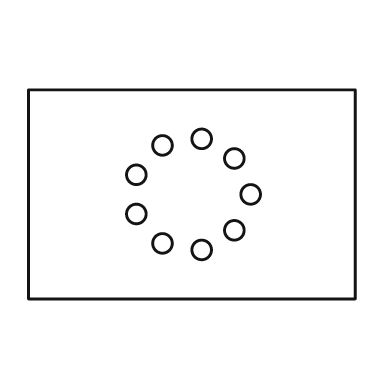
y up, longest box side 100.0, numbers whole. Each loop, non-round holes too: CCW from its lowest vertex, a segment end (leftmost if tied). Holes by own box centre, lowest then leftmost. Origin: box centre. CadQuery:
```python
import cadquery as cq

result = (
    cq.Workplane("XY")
    .moveTo(-50.0, -32.0)
    .lineTo(50.0, -32.0)
    .lineTo(50.0, 32.0)
    .lineTo(-50.0, 32.0)
    .close()
    .moveTo(3.0, -17.0)
    .circle(3.0)
    .moveTo(-9.0, -15.0)
    .circle(3.0)
    .moveTo(13.0, -11.0)
    .circle(3.0)
    .moveTo(-17.0, -6.0)
    .circle(3.0)
    .moveTo(18.0, 0.0)
    .circle(3.0)
    .moveTo(-17.0, 6.0)
    .circle(3.0)
    .moveTo(13.0, 11.0)
    .circle(3.0)
    .moveTo(-9.0, 15.0)
    .circle(3.0)
    .moveTo(3.0, 17.0)
    .circle(3.0)
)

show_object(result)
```